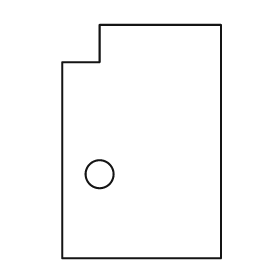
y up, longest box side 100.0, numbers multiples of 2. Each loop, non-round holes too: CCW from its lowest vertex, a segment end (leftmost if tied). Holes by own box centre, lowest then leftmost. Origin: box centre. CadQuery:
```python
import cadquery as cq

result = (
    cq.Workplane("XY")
    .moveTo(-34.0, -50.0)
    .lineTo(34.0, -50.0)
    .lineTo(34.0, 50.0)
    .lineTo(-18.0, 50.0)
    .lineTo(-18.0, 34.0)
    .lineTo(-34.0, 34.0)
    .close()
    .moveTo(-18.0, -14.0)
    .circle(6.0)
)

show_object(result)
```